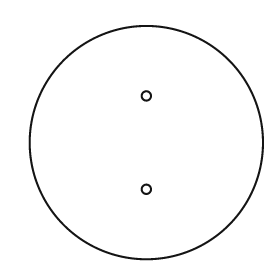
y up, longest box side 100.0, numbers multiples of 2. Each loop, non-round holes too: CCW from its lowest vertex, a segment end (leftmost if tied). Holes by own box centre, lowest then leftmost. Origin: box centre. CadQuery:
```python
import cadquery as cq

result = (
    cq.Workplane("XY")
    .moveTo(0.0, 0.0)
    .circle(50.0)
    .moveTo(0.0, -20.0)
    .circle(2.0)
    .moveTo(0.0, 20.0)
    .circle(2.0)
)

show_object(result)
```